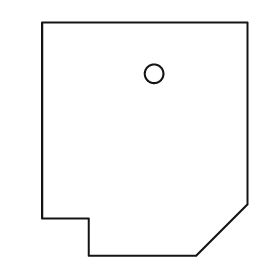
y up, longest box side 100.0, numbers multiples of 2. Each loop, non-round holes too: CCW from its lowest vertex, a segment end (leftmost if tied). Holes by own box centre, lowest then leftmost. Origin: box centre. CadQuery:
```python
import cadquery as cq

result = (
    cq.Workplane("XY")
    .moveTo(-24.0, -50.0)
    .lineTo(22.0, -50.0)
    .lineTo(44.0, -28.0)
    .lineTo(44.0, 50.0)
    .lineTo(-44.0, 50.0)
    .lineTo(-44.0, -34.0)
    .lineTo(-24.0, -34.0)
    .close()
    .moveTo(4.0, 28.0)
    .circle(4.0)
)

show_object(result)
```